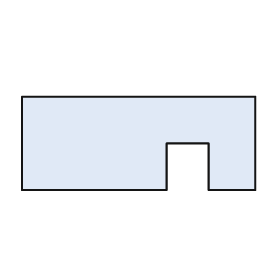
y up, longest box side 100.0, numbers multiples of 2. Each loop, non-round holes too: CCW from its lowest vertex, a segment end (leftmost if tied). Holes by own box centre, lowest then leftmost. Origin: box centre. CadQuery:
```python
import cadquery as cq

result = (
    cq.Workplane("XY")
    .moveTo(-50.0, -20.0)
    .lineTo(12.0, -20.0)
    .lineTo(12.0, 0.0)
    .lineTo(30.0, 0.0)
    .lineTo(30.0, -20.0)
    .lineTo(50.0, -20.0)
    .lineTo(50.0, 20.0)
    .lineTo(-50.0, 20.0)
    .close()
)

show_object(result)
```